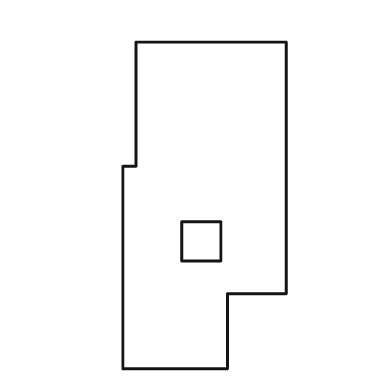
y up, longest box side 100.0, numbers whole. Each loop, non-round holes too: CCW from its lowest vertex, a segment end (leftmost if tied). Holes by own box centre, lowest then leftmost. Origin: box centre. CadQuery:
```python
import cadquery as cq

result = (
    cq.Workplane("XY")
    .moveTo(-25.0, -50.0)
    .lineTo(7.0, -50.0)
    .lineTo(7.0, -27.0)
    .lineTo(25.0, -27.0)
    .lineTo(25.0, 50.0)
    .lineTo(-21.0, 50.0)
    .lineTo(-21.0, 12.0)
    .lineTo(-25.0, 12.0)
    .close()
    .moveTo(-7.0, -17.0)
    .lineTo(5.0, -17.0)
    .lineTo(5.0, -5.0)
    .lineTo(-7.0, -5.0)
    .close()
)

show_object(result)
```